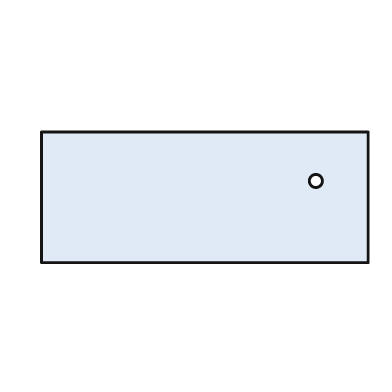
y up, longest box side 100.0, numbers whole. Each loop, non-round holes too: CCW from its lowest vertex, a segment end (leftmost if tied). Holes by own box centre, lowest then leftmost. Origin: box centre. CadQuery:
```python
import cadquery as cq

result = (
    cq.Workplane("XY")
    .moveTo(-50.0, -20.0)
    .lineTo(50.0, -20.0)
    .lineTo(50.0, 20.0)
    .lineTo(-50.0, 20.0)
    .close()
    .moveTo(34.0, 5.0)
    .circle(2.0)
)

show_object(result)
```